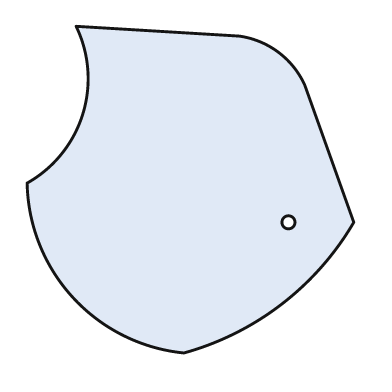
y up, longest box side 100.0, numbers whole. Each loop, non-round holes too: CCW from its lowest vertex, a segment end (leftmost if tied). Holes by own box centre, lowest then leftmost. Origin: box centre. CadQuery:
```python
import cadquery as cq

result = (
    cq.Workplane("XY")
    .moveTo(-2.0, -50.0)
    .threePointArc((28.0, -35.0), (50.0, -10.0))
    .lineTo(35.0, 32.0)
    .threePointArc((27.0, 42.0), (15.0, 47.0))
    .lineTo(-35.0, 50.0)
    .threePointArc((-33.0, 23.0), (-50.0, 2.0))
    .threePointArc((-36.0, -33.0), (-2.0, -50.0))
    .close()
    .moveTo(30.0, -10.0)
    .circle(2.0)
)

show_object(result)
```